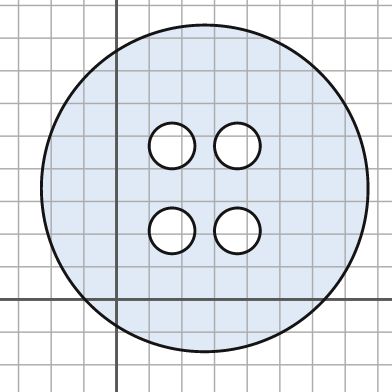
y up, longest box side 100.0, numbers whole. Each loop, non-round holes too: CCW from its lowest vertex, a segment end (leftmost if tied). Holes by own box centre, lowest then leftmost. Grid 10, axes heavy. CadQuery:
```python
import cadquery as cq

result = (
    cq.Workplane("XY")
    .moveTo(27.0, 34.0)
    .circle(50.0)
    .moveTo(17.0, 21.0)
    .circle(7.0)
    .moveTo(37.0, 21.0)
    .circle(7.0)
    .moveTo(17.0, 47.0)
    .circle(7.0)
    .moveTo(37.0, 47.0)
    .circle(7.0)
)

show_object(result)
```